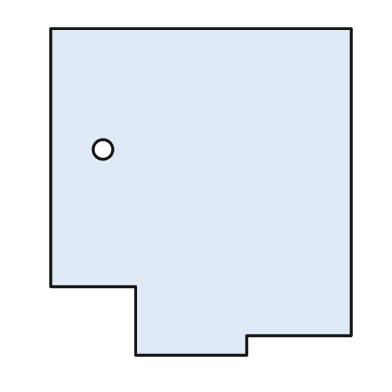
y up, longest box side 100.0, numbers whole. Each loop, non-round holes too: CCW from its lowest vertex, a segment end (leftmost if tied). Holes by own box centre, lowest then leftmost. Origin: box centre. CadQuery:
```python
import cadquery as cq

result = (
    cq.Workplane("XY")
    .moveTo(-20.0, -50.0)
    .lineTo(14.0, -50.0)
    .lineTo(14.0, -44.0)
    .lineTo(46.0, -44.0)
    .lineTo(46.0, 50.0)
    .lineTo(-46.0, 50.0)
    .lineTo(-46.0, -29.0)
    .lineTo(-20.0, -29.0)
    .close()
    .moveTo(-30.0, 13.0)
    .circle(3.0)
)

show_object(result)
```